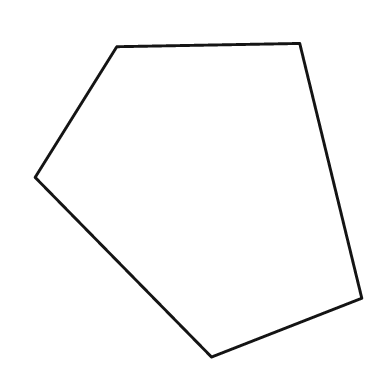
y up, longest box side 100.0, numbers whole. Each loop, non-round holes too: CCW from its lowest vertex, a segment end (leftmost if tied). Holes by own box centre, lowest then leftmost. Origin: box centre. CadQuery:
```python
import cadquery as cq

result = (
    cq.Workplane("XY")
    .moveTo(4.0, -48.0)
    .lineTo(50.0, -30.0)
    .lineTo(31.0, 48.0)
    .lineTo(-25.0, 47.0)
    .lineTo(-50.0, 7.0)
    .close()
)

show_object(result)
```